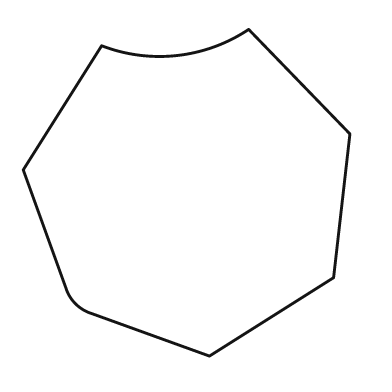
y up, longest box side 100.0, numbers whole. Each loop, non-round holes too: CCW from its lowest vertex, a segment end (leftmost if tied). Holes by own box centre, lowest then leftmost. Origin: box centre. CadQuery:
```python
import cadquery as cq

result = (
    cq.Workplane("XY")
    .moveTo(7.0, -50.0)
    .lineTo(45.0, -26.0)
    .lineTo(50.0, 18.0)
    .lineTo(19.0, 50.0)
    .threePointArc((-3.0, 42.0), (-26.0, 45.0))
    .lineTo(-50.0, 7.0)
    .lineTo(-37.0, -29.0)
    .threePointArc((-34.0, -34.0), (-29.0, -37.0))
    .close()
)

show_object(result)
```